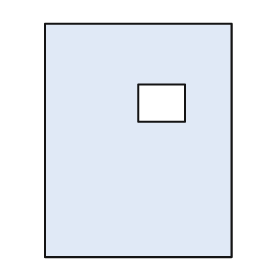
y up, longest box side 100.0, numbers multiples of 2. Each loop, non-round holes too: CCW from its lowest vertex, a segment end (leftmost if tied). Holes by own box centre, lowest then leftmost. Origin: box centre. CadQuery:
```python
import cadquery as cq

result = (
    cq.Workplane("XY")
    .moveTo(-40.0, -50.0)
    .lineTo(40.0, -50.0)
    .lineTo(40.0, 50.0)
    .lineTo(-40.0, 50.0)
    .close()
    .moveTo(0.0, 8.0)
    .lineTo(20.0, 8.0)
    .lineTo(20.0, 24.0)
    .lineTo(0.0, 24.0)
    .close()
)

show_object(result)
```